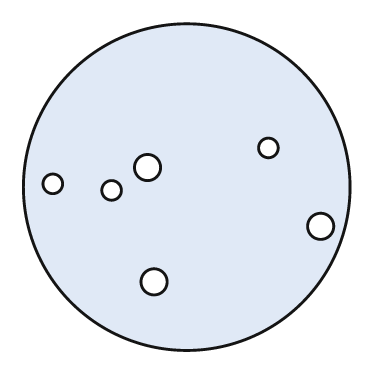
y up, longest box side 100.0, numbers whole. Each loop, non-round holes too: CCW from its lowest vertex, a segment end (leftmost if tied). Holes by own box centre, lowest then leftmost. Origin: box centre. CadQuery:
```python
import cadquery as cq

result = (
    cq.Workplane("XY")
    .moveTo(0.0, 0.0)
    .circle(50.0)
    .moveTo(-10.0, -29.0)
    .circle(4.0)
    .moveTo(41.0, -12.0)
    .circle(4.0)
    .moveTo(-23.0, -1.0)
    .circle(3.0)
    .moveTo(-41.0, 1.0)
    .circle(3.0)
    .moveTo(-12.0, 6.0)
    .circle(4.0)
    .moveTo(25.0, 12.0)
    .circle(3.0)
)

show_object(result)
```